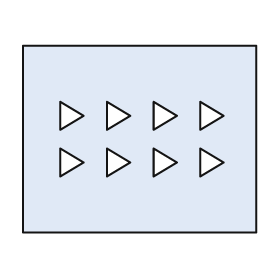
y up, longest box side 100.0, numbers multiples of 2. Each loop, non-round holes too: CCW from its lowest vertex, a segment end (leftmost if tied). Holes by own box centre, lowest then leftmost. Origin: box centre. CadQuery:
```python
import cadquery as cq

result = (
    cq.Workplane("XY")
    .moveTo(-50.0, -40.0)
    .lineTo(50.0, -40.0)
    .lineTo(50.0, 40.0)
    .lineTo(-50.0, 40.0)
    .close()
    .moveTo(-34.0, -16.0)
    .lineTo(-24.0, -10.0)
    .lineTo(-34.0, -4.0)
    .close()
    .moveTo(-14.0, -16.0)
    .lineTo(-4.0, -10.0)
    .lineTo(-14.0, -4.0)
    .close()
    .moveTo(6.0, -16.0)
    .lineTo(16.0, -10.0)
    .lineTo(6.0, -4.0)
    .close()
    .moveTo(26.0, -16.0)
    .lineTo(36.0, -10.0)
    .lineTo(26.0, -4.0)
    .close()
    .moveTo(-34.0, 4.0)
    .lineTo(-24.0, 10.0)
    .lineTo(-34.0, 16.0)
    .close()
    .moveTo(-14.0, 4.0)
    .lineTo(-4.0, 10.0)
    .lineTo(-14.0, 16.0)
    .close()
    .moveTo(6.0, 4.0)
    .lineTo(16.0, 10.0)
    .lineTo(6.0, 16.0)
    .close()
    .moveTo(26.0, 4.0)
    .lineTo(36.0, 10.0)
    .lineTo(26.0, 16.0)
    .close()
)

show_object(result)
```